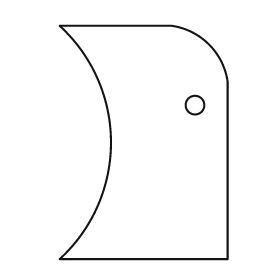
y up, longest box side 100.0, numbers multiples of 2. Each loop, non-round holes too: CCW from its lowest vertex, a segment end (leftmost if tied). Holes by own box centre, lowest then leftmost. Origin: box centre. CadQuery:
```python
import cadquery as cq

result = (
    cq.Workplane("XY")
    .moveTo(-36.0, -50.0)
    .lineTo(36.0, -50.0)
    .lineTo(36.0, 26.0)
    .threePointArc((28.0, 42.0), (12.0, 50.0))
    .lineTo(-36.0, 50.0)
    .threePointArc((-14.0, 0.0), (-36.0, -50.0))
    .close()
    .moveTo(22.0, 16.0)
    .circle(4.0)
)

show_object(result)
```